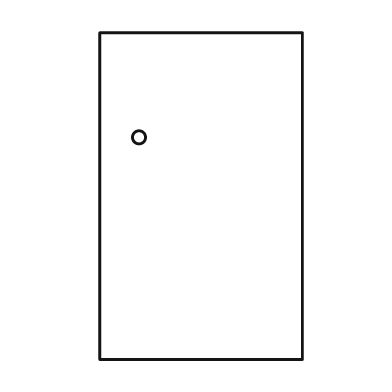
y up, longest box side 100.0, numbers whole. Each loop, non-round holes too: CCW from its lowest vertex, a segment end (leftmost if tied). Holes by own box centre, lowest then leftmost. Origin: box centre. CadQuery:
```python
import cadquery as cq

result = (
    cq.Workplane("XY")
    .moveTo(-31.0, -50.0)
    .lineTo(31.0, -50.0)
    .lineTo(31.0, 50.0)
    .lineTo(-31.0, 50.0)
    .close()
    .moveTo(-19.0, 18.0)
    .circle(2.0)
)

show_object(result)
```